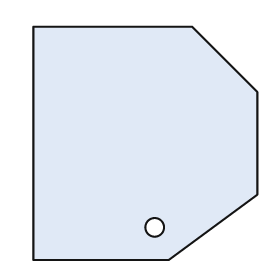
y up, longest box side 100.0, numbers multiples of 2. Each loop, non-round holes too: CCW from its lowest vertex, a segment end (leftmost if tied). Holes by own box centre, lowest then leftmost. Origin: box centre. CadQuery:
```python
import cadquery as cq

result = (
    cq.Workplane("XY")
    .moveTo(-48.0, -50.0)
    .lineTo(10.0, -50.0)
    .lineTo(48.0, -22.0)
    .lineTo(48.0, 22.0)
    .lineTo(20.0, 50.0)
    .lineTo(-48.0, 50.0)
    .close()
    .moveTo(4.0, -36.0)
    .circle(4.0)
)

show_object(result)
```